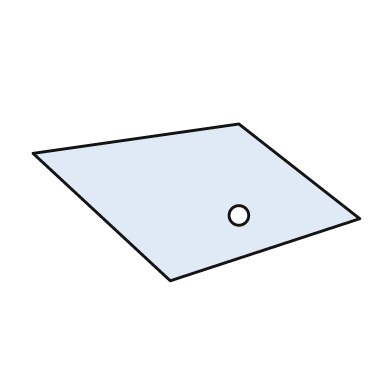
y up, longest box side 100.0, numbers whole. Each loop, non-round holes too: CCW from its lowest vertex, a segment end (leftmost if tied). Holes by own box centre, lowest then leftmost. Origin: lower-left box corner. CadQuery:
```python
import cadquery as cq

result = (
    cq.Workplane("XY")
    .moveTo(42.0, 0.0)
    .lineTo(100.0, 19.0)
    .lineTo(63.0, 48.0)
    .lineTo(0.0, 39.0)
    .close()
    .moveTo(63.0, 20.0)
    .circle(3.0)
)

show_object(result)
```